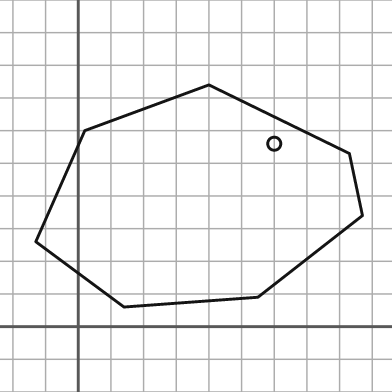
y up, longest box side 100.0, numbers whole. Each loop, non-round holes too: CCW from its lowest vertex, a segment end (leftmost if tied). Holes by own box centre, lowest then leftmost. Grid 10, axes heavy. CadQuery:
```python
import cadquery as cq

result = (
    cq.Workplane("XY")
    .moveTo(14.0, 6.0)
    .lineTo(55.0, 9.0)
    .lineTo(87.0, 34.0)
    .lineTo(83.0, 53.0)
    .lineTo(40.0, 74.0)
    .lineTo(2.0, 60.0)
    .lineTo(-13.0, 26.0)
    .close()
    .moveTo(60.0, 56.0)
    .circle(2.0)
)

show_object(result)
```